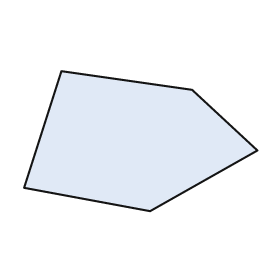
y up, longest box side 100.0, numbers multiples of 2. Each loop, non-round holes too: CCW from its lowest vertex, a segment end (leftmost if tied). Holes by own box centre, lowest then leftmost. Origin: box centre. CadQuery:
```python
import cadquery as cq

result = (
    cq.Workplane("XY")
    .moveTo(4.0, -30.0)
    .lineTo(50.0, -4.0)
    .lineTo(22.0, 22.0)
    .lineTo(-34.0, 30.0)
    .lineTo(-50.0, -20.0)
    .close()
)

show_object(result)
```